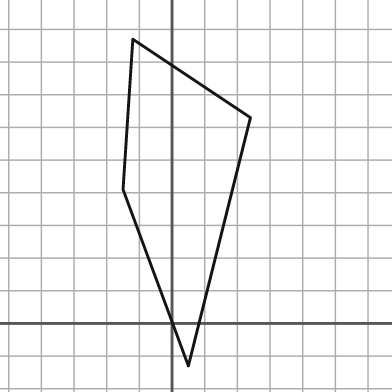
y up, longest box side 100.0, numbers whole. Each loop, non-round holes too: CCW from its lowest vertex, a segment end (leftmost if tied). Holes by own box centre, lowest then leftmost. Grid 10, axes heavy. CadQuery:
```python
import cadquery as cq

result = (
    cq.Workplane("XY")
    .moveTo(5.0, -13.0)
    .lineTo(24.0, 63.0)
    .lineTo(-12.0, 87.0)
    .lineTo(-15.0, 41.0)
    .close()
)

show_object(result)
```